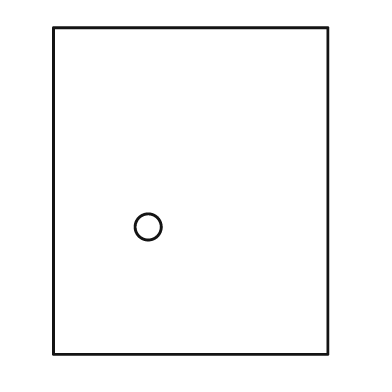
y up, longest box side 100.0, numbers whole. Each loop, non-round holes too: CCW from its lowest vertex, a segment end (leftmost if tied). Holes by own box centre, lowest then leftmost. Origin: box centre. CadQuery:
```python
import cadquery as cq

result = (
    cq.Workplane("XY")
    .moveTo(-42.0, -50.0)
    .lineTo(42.0, -50.0)
    .lineTo(42.0, 50.0)
    .lineTo(-42.0, 50.0)
    .close()
    .moveTo(-13.0, -11.0)
    .circle(4.0)
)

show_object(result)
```